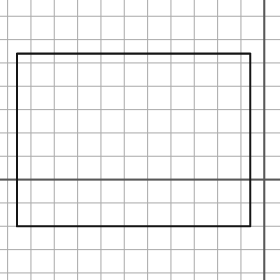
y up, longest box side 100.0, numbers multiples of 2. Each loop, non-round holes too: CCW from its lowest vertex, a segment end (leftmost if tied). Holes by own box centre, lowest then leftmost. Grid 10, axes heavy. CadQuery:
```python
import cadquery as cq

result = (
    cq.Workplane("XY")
    .moveTo(-106.0, -20.0)
    .lineTo(-6.0, -20.0)
    .lineTo(-6.0, 54.0)
    .lineTo(-106.0, 54.0)
    .close()
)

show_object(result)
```